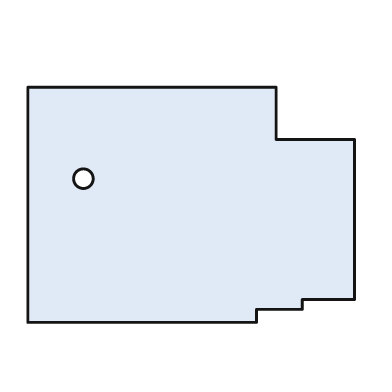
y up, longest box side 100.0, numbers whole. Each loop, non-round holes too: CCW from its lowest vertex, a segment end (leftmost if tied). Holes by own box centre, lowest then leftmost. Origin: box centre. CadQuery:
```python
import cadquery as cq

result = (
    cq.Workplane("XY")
    .moveTo(-50.0, -36.0)
    .lineTo(20.0, -36.0)
    .lineTo(20.0, -32.0)
    .lineTo(34.0, -32.0)
    .lineTo(34.0, -29.0)
    .lineTo(50.0, -29.0)
    .lineTo(50.0, 20.0)
    .lineTo(26.0, 20.0)
    .lineTo(26.0, 36.0)
    .lineTo(-50.0, 36.0)
    .close()
    .moveTo(-33.0, 8.0)
    .circle(3.0)
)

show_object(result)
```